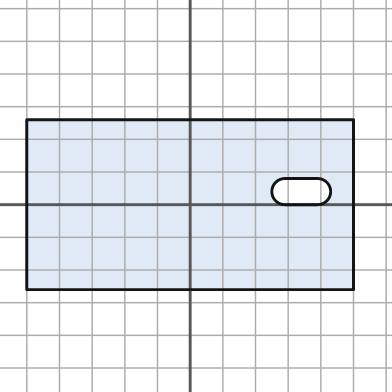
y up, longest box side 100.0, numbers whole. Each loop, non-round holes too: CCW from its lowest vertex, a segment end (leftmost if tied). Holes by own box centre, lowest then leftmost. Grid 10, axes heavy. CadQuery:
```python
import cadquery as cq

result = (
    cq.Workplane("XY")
    .moveTo(-50.0, -26.0)
    .lineTo(50.0, -26.0)
    .lineTo(50.0, 26.0)
    .lineTo(-50.0, 26.0)
    .close()
    .moveTo(29.0, 0.0)
    .lineTo(39.0, 0.0)
    .threePointArc((43.0, 4.0), (39.0, 8.0))
    .lineTo(29.0, 8.0)
    .threePointArc((25.0, 4.0), (29.0, 0.0))
    .close()
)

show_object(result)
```